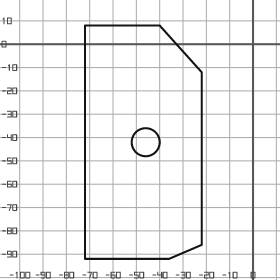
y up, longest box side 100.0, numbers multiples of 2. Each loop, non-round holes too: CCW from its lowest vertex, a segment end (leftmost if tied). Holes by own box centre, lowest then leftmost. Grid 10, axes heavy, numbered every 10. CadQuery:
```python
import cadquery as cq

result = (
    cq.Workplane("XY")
    .moveTo(-72.0, -92.0)
    .lineTo(-36.0, -92.0)
    .lineTo(-22.0, -86.0)
    .lineTo(-22.0, -12.0)
    .lineTo(-40.0, 8.0)
    .lineTo(-72.0, 8.0)
    .close()
    .moveTo(-46.0, -42.0)
    .circle(6.0)
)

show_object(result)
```